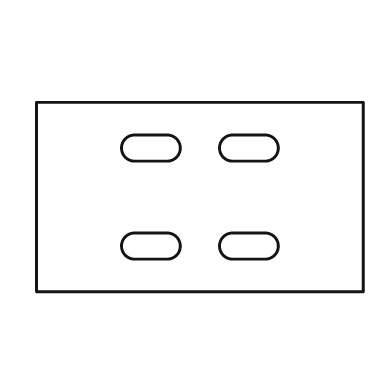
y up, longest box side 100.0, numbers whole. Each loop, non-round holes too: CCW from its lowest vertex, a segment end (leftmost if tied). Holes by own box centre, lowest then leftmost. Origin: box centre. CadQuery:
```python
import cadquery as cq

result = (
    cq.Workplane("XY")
    .moveTo(-50.0, -29.0)
    .lineTo(50.0, -29.0)
    .lineTo(50.0, 29.0)
    .lineTo(-50.0, 29.0)
    .close()
    .moveTo(-20.0, -19.0)
    .lineTo(-10.0, -19.0)
    .threePointArc((-6.0, -15.0), (-10.0, -11.0))
    .lineTo(-20.0, -11.0)
    .threePointArc((-24.0, -15.0), (-20.0, -19.0))
    .close()
    .moveTo(10.0, -19.0)
    .lineTo(20.0, -19.0)
    .threePointArc((24.0, -15.0), (20.0, -11.0))
    .lineTo(10.0, -11.0)
    .threePointArc((6.0, -15.0), (10.0, -19.0))
    .close()
    .moveTo(-20.0, 11.0)
    .lineTo(-10.0, 11.0)
    .threePointArc((-6.0, 15.0), (-10.0, 19.0))
    .lineTo(-20.0, 19.0)
    .threePointArc((-24.0, 15.0), (-20.0, 11.0))
    .close()
    .moveTo(10.0, 11.0)
    .lineTo(20.0, 11.0)
    .threePointArc((24.0, 15.0), (20.0, 19.0))
    .lineTo(10.0, 19.0)
    .threePointArc((6.0, 15.0), (10.0, 11.0))
    .close()
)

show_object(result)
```